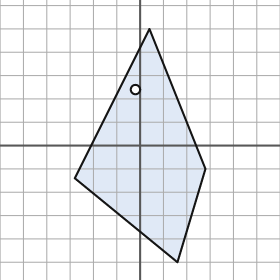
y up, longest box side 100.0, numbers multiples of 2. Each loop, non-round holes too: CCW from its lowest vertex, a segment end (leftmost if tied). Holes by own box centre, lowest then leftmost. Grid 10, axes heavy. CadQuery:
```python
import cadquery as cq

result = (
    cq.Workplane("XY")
    .moveTo(16.0, -50.0)
    .lineTo(28.0, -10.0)
    .lineTo(4.0, 50.0)
    .lineTo(-28.0, -14.0)
    .close()
    .moveTo(-2.0, 24.0)
    .circle(2.0)
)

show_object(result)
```